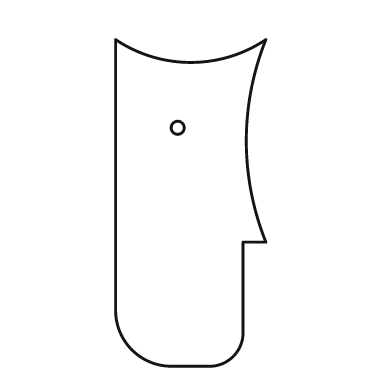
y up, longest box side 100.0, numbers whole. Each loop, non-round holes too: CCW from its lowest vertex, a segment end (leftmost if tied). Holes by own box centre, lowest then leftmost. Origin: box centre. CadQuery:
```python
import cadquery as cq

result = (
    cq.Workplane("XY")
    .moveTo(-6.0, -50.0)
    .lineTo(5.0, -50.0)
    .threePointArc((13.0, -47.0), (16.0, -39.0))
    .lineTo(16.0, -12.0)
    .lineTo(23.0, -12.0)
    .threePointArc((17.0, 19.0), (23.0, 50.0))
    .threePointArc((0.0, 43.0), (-23.0, 50.0))
    .lineTo(-23.0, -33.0)
    .threePointArc((-18.0, -45.0), (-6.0, -50.0))
    .close()
    .moveTo(-4.0, 23.0)
    .circle(2.0)
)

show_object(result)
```